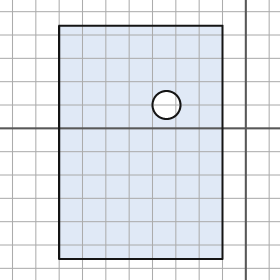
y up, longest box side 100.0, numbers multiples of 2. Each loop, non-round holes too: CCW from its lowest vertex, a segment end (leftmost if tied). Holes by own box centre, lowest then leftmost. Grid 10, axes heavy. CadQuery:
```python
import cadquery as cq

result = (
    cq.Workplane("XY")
    .moveTo(-80.0, -56.0)
    .lineTo(-10.0, -56.0)
    .lineTo(-10.0, 44.0)
    .lineTo(-80.0, 44.0)
    .close()
    .moveTo(-34.0, 10.0)
    .circle(6.0)
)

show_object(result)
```